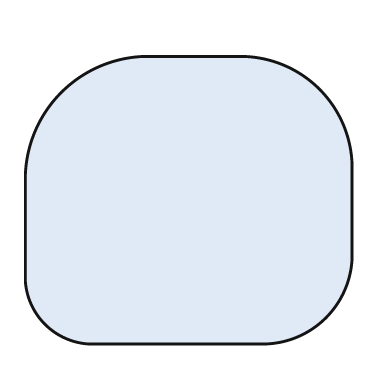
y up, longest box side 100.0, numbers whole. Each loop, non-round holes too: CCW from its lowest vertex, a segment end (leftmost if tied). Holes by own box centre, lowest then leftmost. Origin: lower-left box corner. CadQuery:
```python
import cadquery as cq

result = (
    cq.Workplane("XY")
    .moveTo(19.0, 0.0)
    .lineTo(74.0, 0.0)
    .threePointArc((92.0, 8.0), (100.0, 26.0))
    .lineTo(100.0, 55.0)
    .threePointArc((90.0, 78.0), (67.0, 88.0))
    .lineTo(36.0, 88.0)
    .threePointArc((11.0, 77.0), (0.0, 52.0))
    .lineTo(0.0, 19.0)
    .threePointArc((6.0, 6.0), (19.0, 0.0))
    .close()
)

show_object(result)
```